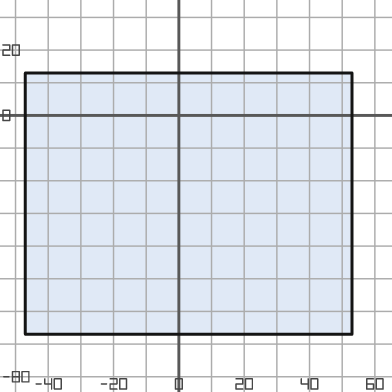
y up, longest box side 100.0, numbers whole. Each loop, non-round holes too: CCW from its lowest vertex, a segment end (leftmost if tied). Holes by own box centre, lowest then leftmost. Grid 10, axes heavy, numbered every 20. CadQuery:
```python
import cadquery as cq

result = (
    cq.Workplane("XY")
    .moveTo(-47.0, -67.0)
    .lineTo(53.0, -67.0)
    .lineTo(53.0, 13.0)
    .lineTo(-47.0, 13.0)
    .close()
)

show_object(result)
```